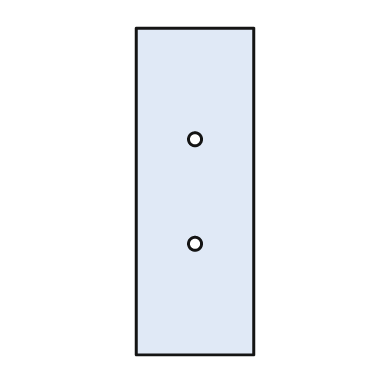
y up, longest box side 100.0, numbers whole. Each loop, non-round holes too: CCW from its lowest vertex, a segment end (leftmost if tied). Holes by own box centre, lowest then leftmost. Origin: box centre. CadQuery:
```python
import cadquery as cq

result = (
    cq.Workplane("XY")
    .moveTo(-18.0, -50.0)
    .lineTo(18.0, -50.0)
    .lineTo(18.0, 50.0)
    .lineTo(-18.0, 50.0)
    .close()
    .moveTo(0.0, -16.0)
    .circle(2.0)
    .moveTo(0.0, 16.0)
    .circle(2.0)
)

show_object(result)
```